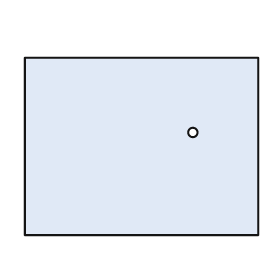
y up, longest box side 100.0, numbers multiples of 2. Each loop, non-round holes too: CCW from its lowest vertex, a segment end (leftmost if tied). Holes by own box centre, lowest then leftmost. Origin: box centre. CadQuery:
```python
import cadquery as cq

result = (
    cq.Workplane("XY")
    .moveTo(-50.0, -38.0)
    .lineTo(50.0, -38.0)
    .lineTo(50.0, 38.0)
    .lineTo(-50.0, 38.0)
    .close()
    .moveTo(22.0, 6.0)
    .circle(2.0)
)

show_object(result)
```